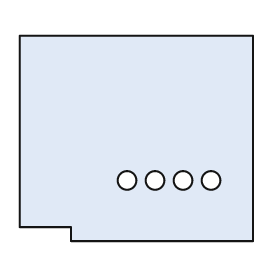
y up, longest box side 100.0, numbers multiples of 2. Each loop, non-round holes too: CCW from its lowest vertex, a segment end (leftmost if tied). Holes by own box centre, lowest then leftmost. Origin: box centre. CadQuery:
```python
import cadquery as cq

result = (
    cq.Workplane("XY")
    .moveTo(-28.0, -44.0)
    .lineTo(50.0, -44.0)
    .lineTo(50.0, 44.0)
    .lineTo(-50.0, 44.0)
    .lineTo(-50.0, -38.0)
    .lineTo(-28.0, -38.0)
    .close()
    .moveTo(-4.0, -18.0)
    .circle(4.0)
    .moveTo(8.0, -18.0)
    .circle(4.0)
    .moveTo(20.0, -18.0)
    .circle(4.0)
    .moveTo(32.0, -18.0)
    .circle(4.0)
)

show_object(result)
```